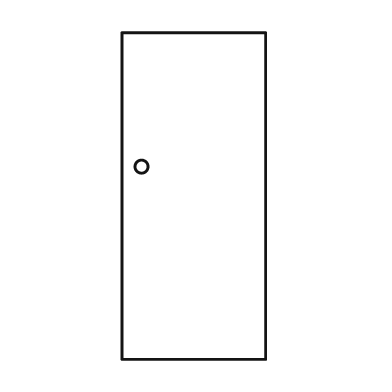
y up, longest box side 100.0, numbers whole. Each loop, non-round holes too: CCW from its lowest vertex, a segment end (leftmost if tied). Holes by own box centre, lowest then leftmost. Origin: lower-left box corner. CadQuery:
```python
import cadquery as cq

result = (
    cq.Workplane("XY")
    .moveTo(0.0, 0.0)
    .lineTo(44.0, 0.0)
    .lineTo(44.0, 100.0)
    .lineTo(0.0, 100.0)
    .close()
    .moveTo(6.0, 59.0)
    .circle(2.0)
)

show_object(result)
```